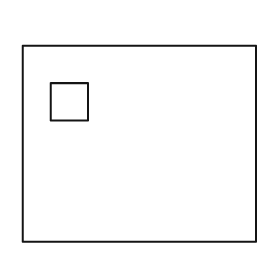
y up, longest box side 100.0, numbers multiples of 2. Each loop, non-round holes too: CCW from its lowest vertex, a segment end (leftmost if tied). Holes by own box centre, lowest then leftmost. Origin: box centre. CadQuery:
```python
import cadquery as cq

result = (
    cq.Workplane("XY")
    .moveTo(-50.0, -42.0)
    .lineTo(50.0, -42.0)
    .lineTo(50.0, 42.0)
    .lineTo(-50.0, 42.0)
    .close()
    .moveTo(-38.0, 10.0)
    .lineTo(-22.0, 10.0)
    .lineTo(-22.0, 26.0)
    .lineTo(-38.0, 26.0)
    .close()
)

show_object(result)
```